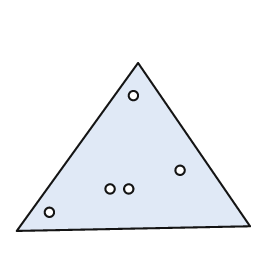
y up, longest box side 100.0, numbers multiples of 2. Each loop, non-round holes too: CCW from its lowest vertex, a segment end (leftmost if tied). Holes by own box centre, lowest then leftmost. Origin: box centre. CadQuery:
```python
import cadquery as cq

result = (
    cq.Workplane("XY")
    .moveTo(-50.0, -36.0)
    .lineTo(50.0, -34.0)
    .lineTo(2.0, 36.0)
    .close()
    .moveTo(-36.0, -28.0)
    .circle(2.0)
    .moveTo(-10.0, -18.0)
    .circle(2.0)
    .moveTo(-2.0, -18.0)
    .circle(2.0)
    .moveTo(20.0, -10.0)
    .circle(2.0)
    .moveTo(0.0, 22.0)
    .circle(2.0)
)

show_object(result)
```